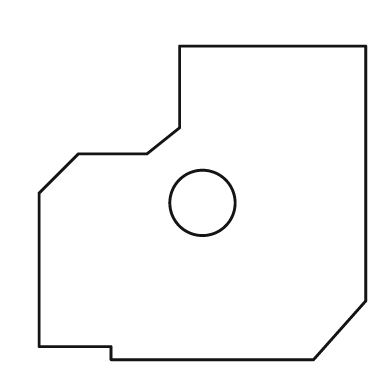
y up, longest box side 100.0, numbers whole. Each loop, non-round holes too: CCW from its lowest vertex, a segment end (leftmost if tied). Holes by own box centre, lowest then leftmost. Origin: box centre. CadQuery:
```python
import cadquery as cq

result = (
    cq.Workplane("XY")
    .moveTo(-28.0, -48.0)
    .lineTo(34.0, -48.0)
    .lineTo(50.0, -30.0)
    .lineTo(50.0, 48.0)
    .lineTo(-7.0, 48.0)
    .lineTo(-7.0, 23.0)
    .lineTo(-17.0, 15.0)
    .lineTo(-38.0, 15.0)
    .lineTo(-50.0, 3.0)
    .lineTo(-50.0, -44.0)
    .lineTo(-28.0, -44.0)
    .close()
    .moveTo(0.0, 0.0)
    .circle(10.0)
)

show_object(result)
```